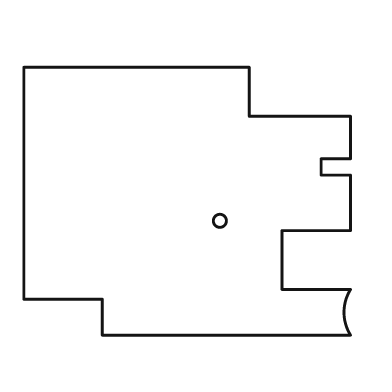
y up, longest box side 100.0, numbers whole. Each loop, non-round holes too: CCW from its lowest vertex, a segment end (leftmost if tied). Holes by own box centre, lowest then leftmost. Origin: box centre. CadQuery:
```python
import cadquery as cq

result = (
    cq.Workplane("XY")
    .moveTo(-26.0, -41.0)
    .lineTo(50.0, -41.0)
    .threePointArc((48.0, -34.0), (50.0, -27.0))
    .lineTo(29.0, -27.0)
    .lineTo(29.0, -9.0)
    .lineTo(50.0, -9.0)
    .lineTo(50.0, 8.0)
    .lineTo(41.0, 8.0)
    .lineTo(41.0, 13.0)
    .lineTo(50.0, 13.0)
    .lineTo(50.0, 26.0)
    .lineTo(19.0, 26.0)
    .lineTo(19.0, 41.0)
    .lineTo(-50.0, 41.0)
    .lineTo(-50.0, -30.0)
    .lineTo(-26.0, -30.0)
    .close()
    .moveTo(10.0, -6.0)
    .circle(2.0)
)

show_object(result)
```